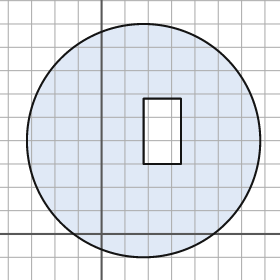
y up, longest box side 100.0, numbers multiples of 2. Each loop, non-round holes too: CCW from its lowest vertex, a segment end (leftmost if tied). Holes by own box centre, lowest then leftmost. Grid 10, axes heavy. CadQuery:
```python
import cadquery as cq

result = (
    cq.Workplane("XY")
    .moveTo(18.0, 40.0)
    .circle(50.0)
    .moveTo(18.0, 30.0)
    .lineTo(34.0, 30.0)
    .lineTo(34.0, 58.0)
    .lineTo(18.0, 58.0)
    .close()
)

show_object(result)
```